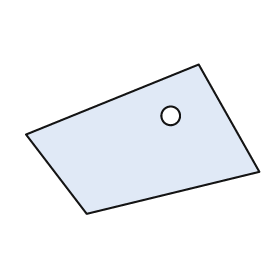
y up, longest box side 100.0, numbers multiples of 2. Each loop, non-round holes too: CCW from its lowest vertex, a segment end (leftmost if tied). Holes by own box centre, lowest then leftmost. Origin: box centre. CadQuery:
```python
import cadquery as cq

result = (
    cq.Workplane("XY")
    .moveTo(-24.0, -32.0)
    .lineTo(50.0, -14.0)
    .lineTo(24.0, 32.0)
    .lineTo(-50.0, 2.0)
    .close()
    .moveTo(12.0, 10.0)
    .circle(4.0)
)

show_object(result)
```